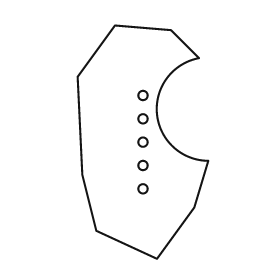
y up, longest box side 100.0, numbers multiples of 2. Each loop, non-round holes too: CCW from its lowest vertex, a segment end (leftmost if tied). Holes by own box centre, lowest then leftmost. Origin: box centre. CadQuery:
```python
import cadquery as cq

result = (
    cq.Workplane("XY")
    .moveTo(6.0, -50.0)
    .lineTo(22.0, -28.0)
    .lineTo(28.0, -8.0)
    .threePointArc((6.0, 12.0), (24.0, 36.0))
    .lineTo(12.0, 48.0)
    .lineTo(-12.0, 50.0)
    .lineTo(-28.0, 28.0)
    .lineTo(-26.0, -14.0)
    .lineTo(-20.0, -38.0)
    .close()
    .moveTo(0.0, -20.0)
    .circle(2.0)
    .moveTo(0.0, -10.0)
    .circle(2.0)
    .moveTo(0.0, 0.0)
    .circle(2.0)
    .moveTo(0.0, 10.0)
    .circle(2.0)
    .moveTo(0.0, 20.0)
    .circle(2.0)
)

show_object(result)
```